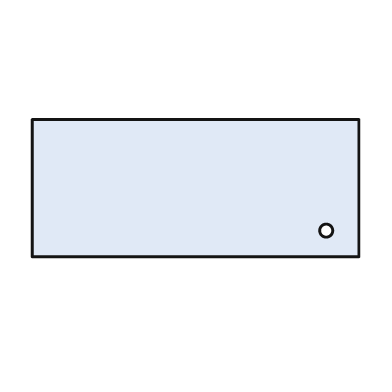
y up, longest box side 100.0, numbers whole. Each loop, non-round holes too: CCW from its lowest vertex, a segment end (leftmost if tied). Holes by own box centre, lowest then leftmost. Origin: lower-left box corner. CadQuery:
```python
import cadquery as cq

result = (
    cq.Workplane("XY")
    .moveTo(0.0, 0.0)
    .lineTo(100.0, 0.0)
    .lineTo(100.0, 42.0)
    .lineTo(0.0, 42.0)
    .close()
    .moveTo(90.0, 8.0)
    .circle(2.0)
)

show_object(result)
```